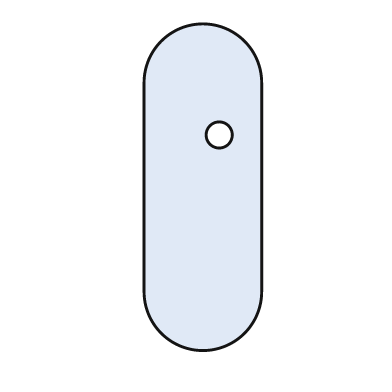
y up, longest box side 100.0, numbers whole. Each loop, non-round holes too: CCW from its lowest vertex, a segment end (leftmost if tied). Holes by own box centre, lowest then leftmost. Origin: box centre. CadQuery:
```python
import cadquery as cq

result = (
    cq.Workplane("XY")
    .moveTo(-18.0, -32.0)
    .threePointArc((0.0, -50.0), (18.0, -32.0))
    .lineTo(18.0, 32.0)
    .threePointArc((0.0, 50.0), (-18.0, 32.0))
    .close()
    .moveTo(5.0, 16.0)
    .circle(4.0)
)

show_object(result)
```